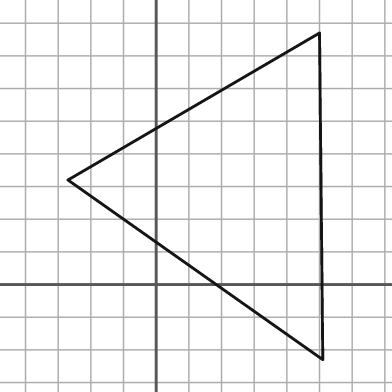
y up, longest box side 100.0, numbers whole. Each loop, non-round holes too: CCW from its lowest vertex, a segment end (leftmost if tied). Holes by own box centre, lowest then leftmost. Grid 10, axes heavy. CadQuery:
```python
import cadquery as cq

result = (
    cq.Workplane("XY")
    .moveTo(51.0, -23.0)
    .lineTo(50.0, 77.0)
    .lineTo(-27.0, 32.0)
    .close()
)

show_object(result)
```